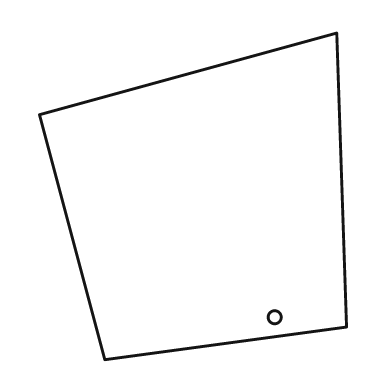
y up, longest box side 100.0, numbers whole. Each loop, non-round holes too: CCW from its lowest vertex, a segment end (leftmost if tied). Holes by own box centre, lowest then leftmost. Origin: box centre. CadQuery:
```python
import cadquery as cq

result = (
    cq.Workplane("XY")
    .moveTo(-27.0, -50.0)
    .lineTo(47.0, -40.0)
    .lineTo(44.0, 50.0)
    .lineTo(-47.0, 25.0)
    .close()
    .moveTo(25.0, -37.0)
    .circle(2.0)
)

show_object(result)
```